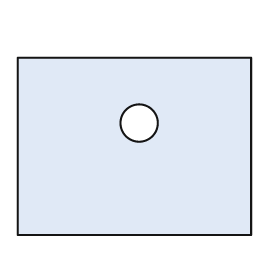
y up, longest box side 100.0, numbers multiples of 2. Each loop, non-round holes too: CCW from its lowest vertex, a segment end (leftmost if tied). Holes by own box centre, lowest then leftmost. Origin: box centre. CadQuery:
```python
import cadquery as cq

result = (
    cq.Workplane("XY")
    .moveTo(-50.0, -38.0)
    .lineTo(50.0, -38.0)
    .lineTo(50.0, 38.0)
    .lineTo(-50.0, 38.0)
    .close()
    .moveTo(2.0, 10.0)
    .circle(8.0)
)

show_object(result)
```